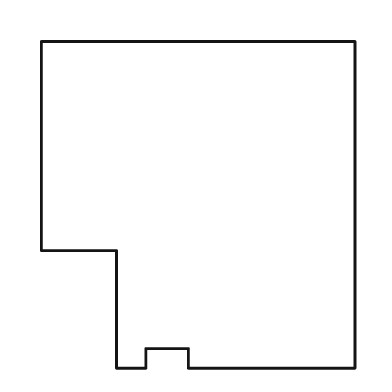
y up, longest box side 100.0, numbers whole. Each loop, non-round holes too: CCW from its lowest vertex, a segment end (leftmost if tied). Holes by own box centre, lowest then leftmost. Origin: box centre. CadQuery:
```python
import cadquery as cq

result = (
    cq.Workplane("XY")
    .moveTo(-25.0, -50.0)
    .lineTo(-16.0, -50.0)
    .lineTo(-16.0, -44.0)
    .lineTo(-3.0, -44.0)
    .lineTo(-3.0, -50.0)
    .lineTo(48.0, -50.0)
    .lineTo(48.0, 50.0)
    .lineTo(-48.0, 50.0)
    .lineTo(-48.0, -14.0)
    .lineTo(-25.0, -14.0)
    .close()
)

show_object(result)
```